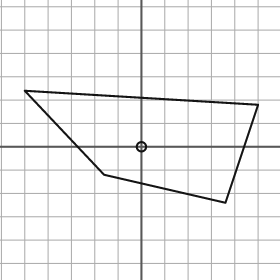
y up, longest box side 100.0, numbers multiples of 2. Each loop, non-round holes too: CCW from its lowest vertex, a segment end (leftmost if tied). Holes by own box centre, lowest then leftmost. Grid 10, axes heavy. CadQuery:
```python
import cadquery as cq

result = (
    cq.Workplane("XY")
    .moveTo(36.0, -24.0)
    .lineTo(50.0, 18.0)
    .lineTo(-50.0, 24.0)
    .lineTo(-16.0, -12.0)
    .close()
    .moveTo(0.0, 0.0)
    .circle(2.0)
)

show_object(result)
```